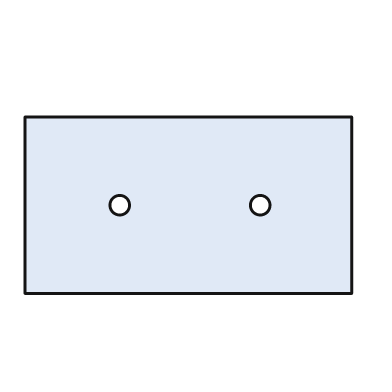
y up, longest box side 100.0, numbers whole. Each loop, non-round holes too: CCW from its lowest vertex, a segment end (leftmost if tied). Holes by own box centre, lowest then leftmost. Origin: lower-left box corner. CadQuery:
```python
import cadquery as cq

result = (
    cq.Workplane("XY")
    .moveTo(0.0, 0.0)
    .lineTo(100.0, 0.0)
    .lineTo(100.0, 54.0)
    .lineTo(0.0, 54.0)
    .close()
    .moveTo(29.0, 27.0)
    .circle(3.0)
    .moveTo(72.0, 27.0)
    .circle(3.0)
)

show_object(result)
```